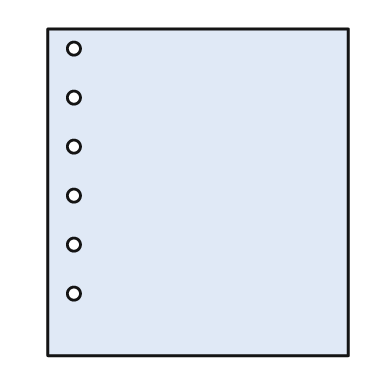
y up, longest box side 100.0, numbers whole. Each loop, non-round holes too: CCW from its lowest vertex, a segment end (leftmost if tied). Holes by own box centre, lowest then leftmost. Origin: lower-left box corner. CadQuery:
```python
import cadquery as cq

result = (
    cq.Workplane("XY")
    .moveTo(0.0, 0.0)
    .lineTo(92.0, 0.0)
    .lineTo(92.0, 100.0)
    .lineTo(0.0, 100.0)
    .close()
    .moveTo(8.0, 19.0)
    .circle(2.0)
    .moveTo(8.0, 34.0)
    .circle(2.0)
    .moveTo(8.0, 49.0)
    .circle(2.0)
    .moveTo(8.0, 64.0)
    .circle(2.0)
    .moveTo(8.0, 79.0)
    .circle(2.0)
    .moveTo(8.0, 94.0)
    .circle(2.0)
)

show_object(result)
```